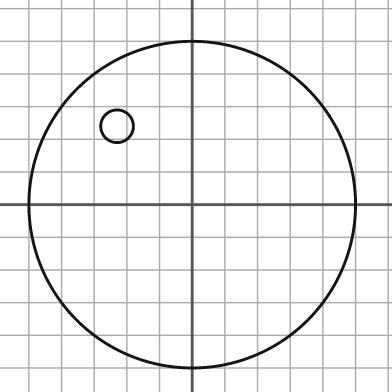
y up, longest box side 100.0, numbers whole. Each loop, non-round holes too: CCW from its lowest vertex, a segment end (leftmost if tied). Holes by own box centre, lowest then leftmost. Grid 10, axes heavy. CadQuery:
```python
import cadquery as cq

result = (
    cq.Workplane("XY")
    .moveTo(0.0, 0.0)
    .circle(50.0)
    .moveTo(-23.0, 24.0)
    .circle(5.0)
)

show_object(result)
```